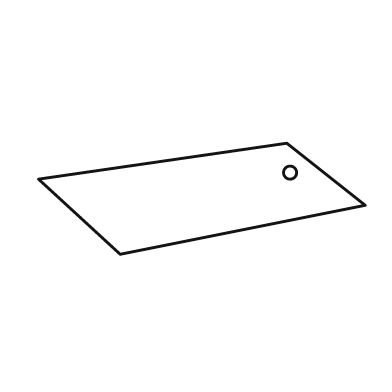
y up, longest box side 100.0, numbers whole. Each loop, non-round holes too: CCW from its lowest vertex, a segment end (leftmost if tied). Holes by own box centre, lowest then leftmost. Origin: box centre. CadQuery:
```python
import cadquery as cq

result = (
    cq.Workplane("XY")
    .moveTo(-25.0, -17.0)
    .lineTo(50.0, -2.0)
    .lineTo(26.0, 17.0)
    .lineTo(-50.0, 6.0)
    .close()
    .moveTo(27.0, 8.0)
    .circle(2.0)
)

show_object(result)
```